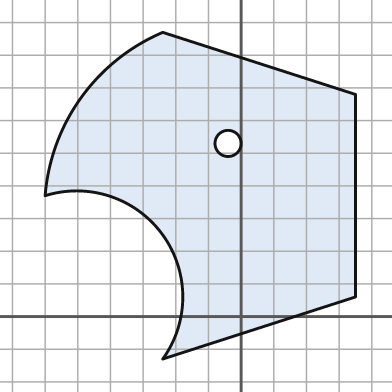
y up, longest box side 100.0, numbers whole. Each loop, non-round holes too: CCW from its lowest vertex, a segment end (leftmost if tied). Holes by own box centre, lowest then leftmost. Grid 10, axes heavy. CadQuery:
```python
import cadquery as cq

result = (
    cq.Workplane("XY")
    .moveTo(-24.0, -13.0)
    .lineTo(35.0, 6.0)
    .lineTo(35.0, 68.0)
    .lineTo(-24.0, 87.0)
    .threePointArc((-49.0, 67.0), (-60.0, 37.0))
    .threePointArc((-24.0, 25.0), (-24.0, -13.0))
    .close()
    .moveTo(-4.0, 53.0)
    .circle(4.0)
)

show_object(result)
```